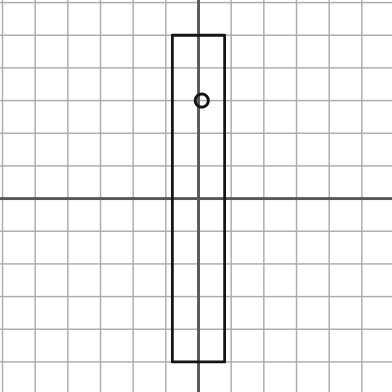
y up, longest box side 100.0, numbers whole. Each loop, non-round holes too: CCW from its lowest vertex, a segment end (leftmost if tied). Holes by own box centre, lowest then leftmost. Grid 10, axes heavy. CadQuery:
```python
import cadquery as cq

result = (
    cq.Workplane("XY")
    .moveTo(-8.0, -50.0)
    .lineTo(8.0, -50.0)
    .lineTo(8.0, 50.0)
    .lineTo(-8.0, 50.0)
    .close()
    .moveTo(1.0, 30.0)
    .circle(2.0)
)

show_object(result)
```